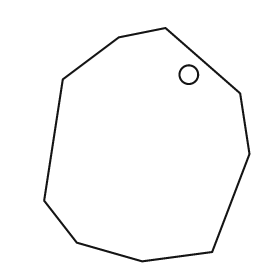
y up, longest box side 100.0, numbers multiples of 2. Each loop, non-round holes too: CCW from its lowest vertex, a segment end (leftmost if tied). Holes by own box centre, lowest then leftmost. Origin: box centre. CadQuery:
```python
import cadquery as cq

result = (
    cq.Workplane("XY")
    .moveTo(-2.0, -50.0)
    .lineTo(28.0, -46.0)
    .lineTo(44.0, -4.0)
    .lineTo(40.0, 22.0)
    .lineTo(8.0, 50.0)
    .lineTo(-12.0, 46.0)
    .lineTo(-36.0, 28.0)
    .lineTo(-44.0, -24.0)
    .lineTo(-30.0, -42.0)
    .close()
    .moveTo(18.0, 30.0)
    .circle(4.0)
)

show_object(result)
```